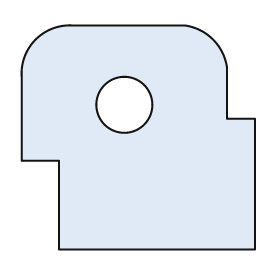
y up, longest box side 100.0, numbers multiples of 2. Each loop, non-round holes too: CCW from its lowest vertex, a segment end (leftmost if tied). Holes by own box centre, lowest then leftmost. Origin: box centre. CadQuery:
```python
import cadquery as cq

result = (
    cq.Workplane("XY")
    .moveTo(-34.0, -48.0)
    .lineTo(50.0, -48.0)
    .lineTo(50.0, 8.0)
    .lineTo(38.0, 8.0)
    .lineTo(38.0, 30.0)
    .threePointArc((32.0, 42.0), (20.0, 48.0))
    .lineTo(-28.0, 48.0)
    .threePointArc((-44.0, 42.0), (-50.0, 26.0))
    .lineTo(-50.0, -10.0)
    .lineTo(-34.0, -10.0)
    .close()
    .moveTo(-6.0, 14.0)
    .circle(12.0)
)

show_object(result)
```